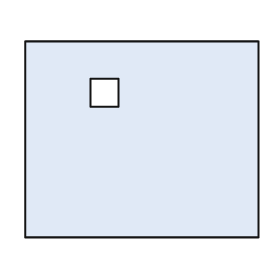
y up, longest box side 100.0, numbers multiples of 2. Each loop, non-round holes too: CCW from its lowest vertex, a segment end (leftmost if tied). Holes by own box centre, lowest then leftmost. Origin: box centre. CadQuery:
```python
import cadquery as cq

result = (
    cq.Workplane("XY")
    .moveTo(-50.0, -42.0)
    .lineTo(50.0, -42.0)
    .lineTo(50.0, 42.0)
    .lineTo(-50.0, 42.0)
    .close()
    .moveTo(-22.0, 14.0)
    .lineTo(-10.0, 14.0)
    .lineTo(-10.0, 26.0)
    .lineTo(-22.0, 26.0)
    .close()
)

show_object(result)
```